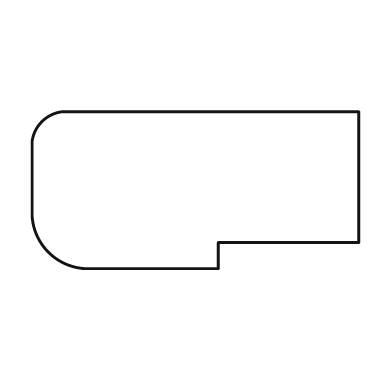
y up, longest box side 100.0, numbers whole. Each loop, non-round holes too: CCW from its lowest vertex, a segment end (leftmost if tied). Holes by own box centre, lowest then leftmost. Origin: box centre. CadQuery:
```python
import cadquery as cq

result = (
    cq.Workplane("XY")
    .moveTo(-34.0, -24.0)
    .lineTo(7.0, -24.0)
    .lineTo(7.0, -16.0)
    .lineTo(50.0, -16.0)
    .lineTo(50.0, 24.0)
    .lineTo(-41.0, 24.0)
    .threePointArc((-47.0, 21.0), (-50.0, 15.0))
    .lineTo(-50.0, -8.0)
    .threePointArc((-45.0, -19.0), (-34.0, -24.0))
    .close()
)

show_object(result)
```